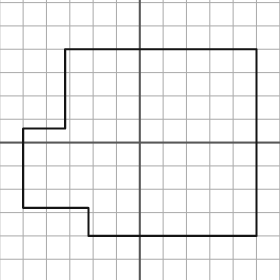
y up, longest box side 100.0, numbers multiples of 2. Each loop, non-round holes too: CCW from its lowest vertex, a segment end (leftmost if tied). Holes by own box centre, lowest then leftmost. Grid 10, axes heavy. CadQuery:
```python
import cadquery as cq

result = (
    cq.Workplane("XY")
    .moveTo(-22.0, -40.0)
    .lineTo(50.0, -40.0)
    .lineTo(50.0, 40.0)
    .lineTo(-32.0, 40.0)
    .lineTo(-32.0, 6.0)
    .lineTo(-50.0, 6.0)
    .lineTo(-50.0, -28.0)
    .lineTo(-22.0, -28.0)
    .close()
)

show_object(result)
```